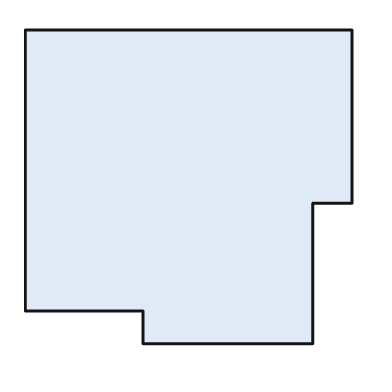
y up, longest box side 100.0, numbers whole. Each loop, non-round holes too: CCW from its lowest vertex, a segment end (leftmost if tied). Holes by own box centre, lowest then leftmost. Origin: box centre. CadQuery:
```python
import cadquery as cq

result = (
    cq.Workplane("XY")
    .moveTo(-14.0, -48.0)
    .lineTo(38.0, -48.0)
    .lineTo(38.0, -5.0)
    .lineTo(50.0, -5.0)
    .lineTo(50.0, 48.0)
    .lineTo(-50.0, 48.0)
    .lineTo(-50.0, -38.0)
    .lineTo(-14.0, -38.0)
    .close()
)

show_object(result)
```